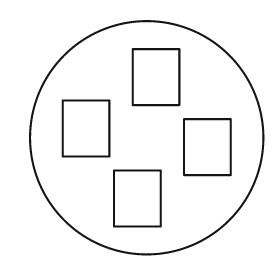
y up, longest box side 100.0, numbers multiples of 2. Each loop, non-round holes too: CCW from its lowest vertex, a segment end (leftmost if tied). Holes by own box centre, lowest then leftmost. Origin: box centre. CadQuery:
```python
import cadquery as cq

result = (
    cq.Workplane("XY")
    .moveTo(0.0, 0.0)
    .circle(50.0)
    .moveTo(-14.0, -38.0)
    .lineTo(6.0, -38.0)
    .lineTo(6.0, -14.0)
    .lineTo(-14.0, -14.0)
    .close()
    .moveTo(16.0, -16.0)
    .lineTo(36.0, -16.0)
    .lineTo(36.0, 8.0)
    .lineTo(16.0, 8.0)
    .close()
    .moveTo(-36.0, -8.0)
    .lineTo(-16.0, -8.0)
    .lineTo(-16.0, 16.0)
    .lineTo(-36.0, 16.0)
    .close()
    .moveTo(-6.0, 14.0)
    .lineTo(14.0, 14.0)
    .lineTo(14.0, 38.0)
    .lineTo(-6.0, 38.0)
    .close()
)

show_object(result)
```